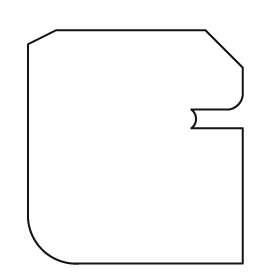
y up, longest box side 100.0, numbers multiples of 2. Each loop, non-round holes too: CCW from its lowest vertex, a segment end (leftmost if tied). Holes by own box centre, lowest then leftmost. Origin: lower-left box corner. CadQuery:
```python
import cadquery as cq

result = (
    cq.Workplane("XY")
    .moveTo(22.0, 0.0)
    .lineTo(92.0, 0.0)
    .lineTo(92.0, 58.0)
    .lineTo(70.0, 58.0)
    .threePointArc((72.0, 62.0), (70.0, 66.0))
    .lineTo(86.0, 66.0)
    .threePointArc((90.0, 68.0), (92.0, 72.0))
    .lineTo(92.0, 84.0)
    .lineTo(76.0, 100.0)
    .lineTo(12.0, 100.0)
    .lineTo(0.0, 94.0)
    .lineTo(0.0, 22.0)
    .threePointArc((6.0, 6.0), (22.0, 0.0))
    .close()
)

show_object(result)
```